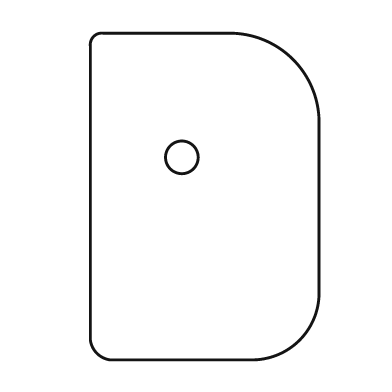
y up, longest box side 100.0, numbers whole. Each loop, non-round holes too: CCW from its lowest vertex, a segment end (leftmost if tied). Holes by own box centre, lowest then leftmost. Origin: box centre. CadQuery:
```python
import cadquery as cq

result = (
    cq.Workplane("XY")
    .moveTo(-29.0, -50.0)
    .lineTo(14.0, -50.0)
    .threePointArc((29.0, -44.0), (35.0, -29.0))
    .lineTo(35.0, 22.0)
    .threePointArc((27.0, 42.0), (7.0, 50.0))
    .lineTo(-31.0, 50.0)
    .threePointArc((-34.0, 49.0), (-35.0, 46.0))
    .lineTo(-35.0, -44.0)
    .threePointArc((-33.0, -48.0), (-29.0, -50.0))
    .close()
    .moveTo(-7.0, 12.0)
    .circle(5.0)
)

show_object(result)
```